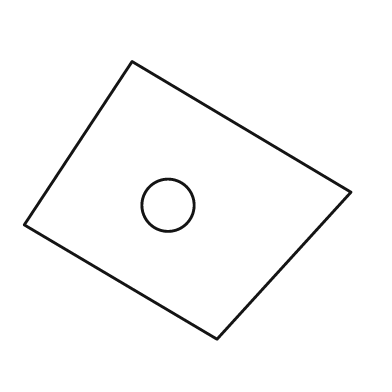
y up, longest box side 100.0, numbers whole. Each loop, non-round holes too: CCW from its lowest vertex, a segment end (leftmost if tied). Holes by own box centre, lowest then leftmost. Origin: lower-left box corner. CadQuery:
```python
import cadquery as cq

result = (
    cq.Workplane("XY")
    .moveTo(59.0, 0.0)
    .lineTo(100.0, 45.0)
    .lineTo(33.0, 85.0)
    .lineTo(0.0, 35.0)
    .close()
    .moveTo(44.0, 41.0)
    .circle(8.0)
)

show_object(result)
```